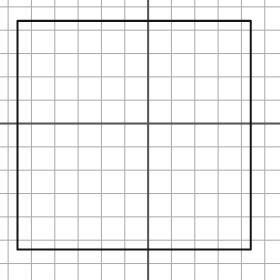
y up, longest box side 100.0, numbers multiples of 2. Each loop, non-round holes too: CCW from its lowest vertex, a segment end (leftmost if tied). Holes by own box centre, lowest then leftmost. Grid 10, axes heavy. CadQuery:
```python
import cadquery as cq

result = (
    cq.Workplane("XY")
    .moveTo(-56.0, -54.0)
    .lineTo(44.0, -54.0)
    .lineTo(44.0, 44.0)
    .lineTo(-56.0, 44.0)
    .close()
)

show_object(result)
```